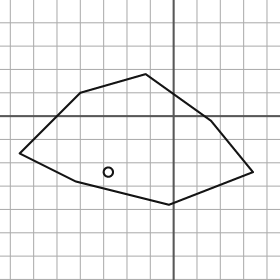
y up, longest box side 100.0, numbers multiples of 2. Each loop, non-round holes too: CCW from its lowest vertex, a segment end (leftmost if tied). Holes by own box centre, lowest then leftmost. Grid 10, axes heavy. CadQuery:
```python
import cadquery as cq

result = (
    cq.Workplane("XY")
    .moveTo(-2.0, -38.0)
    .lineTo(34.0, -24.0)
    .lineTo(16.0, -2.0)
    .lineTo(-12.0, 18.0)
    .lineTo(-40.0, 10.0)
    .lineTo(-66.0, -16.0)
    .lineTo(-42.0, -28.0)
    .close()
    .moveTo(-28.0, -24.0)
    .circle(2.0)
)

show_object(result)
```